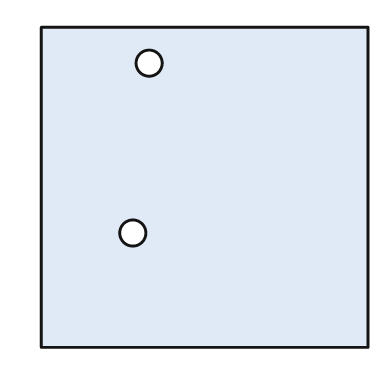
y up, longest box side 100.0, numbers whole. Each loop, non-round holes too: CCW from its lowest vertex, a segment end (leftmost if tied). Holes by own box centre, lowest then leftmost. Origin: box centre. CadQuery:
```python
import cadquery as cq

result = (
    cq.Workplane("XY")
    .moveTo(-50.0, -49.0)
    .lineTo(50.0, -49.0)
    .lineTo(50.0, 49.0)
    .lineTo(-50.0, 49.0)
    .close()
    .moveTo(-22.0, -14.0)
    .circle(4.0)
    .moveTo(-17.0, 38.0)
    .circle(4.0)
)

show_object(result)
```